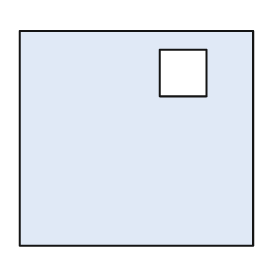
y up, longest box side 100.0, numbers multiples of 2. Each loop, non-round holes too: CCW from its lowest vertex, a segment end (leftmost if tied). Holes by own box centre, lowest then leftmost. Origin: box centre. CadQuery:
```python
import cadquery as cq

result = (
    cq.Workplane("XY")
    .moveTo(-50.0, -46.0)
    .lineTo(50.0, -46.0)
    .lineTo(50.0, 46.0)
    .lineTo(-50.0, 46.0)
    .close()
    .moveTo(10.0, 18.0)
    .lineTo(30.0, 18.0)
    .lineTo(30.0, 38.0)
    .lineTo(10.0, 38.0)
    .close()
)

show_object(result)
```